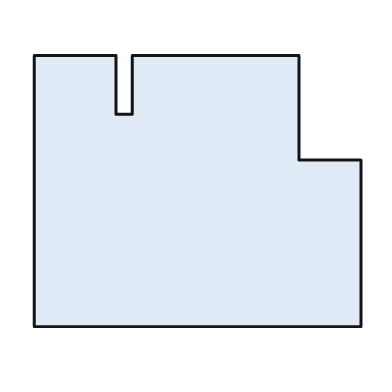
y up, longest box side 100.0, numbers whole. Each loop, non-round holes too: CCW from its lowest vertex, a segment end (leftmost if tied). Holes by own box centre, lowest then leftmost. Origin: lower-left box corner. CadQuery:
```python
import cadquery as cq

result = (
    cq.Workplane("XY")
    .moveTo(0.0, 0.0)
    .lineTo(100.0, 0.0)
    .lineTo(100.0, 51.0)
    .lineTo(81.0, 51.0)
    .lineTo(81.0, 83.0)
    .lineTo(30.0, 83.0)
    .lineTo(30.0, 65.0)
    .lineTo(25.0, 65.0)
    .lineTo(25.0, 83.0)
    .lineTo(0.0, 83.0)
    .close()
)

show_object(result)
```